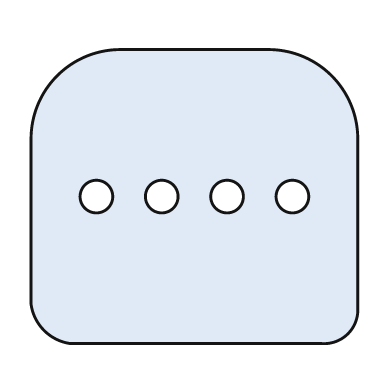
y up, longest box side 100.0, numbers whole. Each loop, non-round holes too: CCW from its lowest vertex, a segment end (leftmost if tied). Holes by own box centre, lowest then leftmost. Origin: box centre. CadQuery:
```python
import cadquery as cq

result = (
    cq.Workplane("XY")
    .moveTo(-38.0, -45.0)
    .lineTo(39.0, -45.0)
    .threePointArc((47.0, -42.0), (50.0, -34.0))
    .lineTo(50.0, 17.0)
    .threePointArc((42.0, 37.0), (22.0, 45.0))
    .lineTo(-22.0, 45.0)
    .threePointArc((-42.0, 37.0), (-50.0, 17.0))
    .lineTo(-50.0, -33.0)
    .threePointArc((-46.0, -41.0), (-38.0, -45.0))
    .close()
    .moveTo(-30.0, 0.0)
    .circle(5.0)
    .moveTo(-10.0, 0.0)
    .circle(5.0)
    .moveTo(10.0, 0.0)
    .circle(5.0)
    .moveTo(30.0, 0.0)
    .circle(5.0)
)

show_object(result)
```